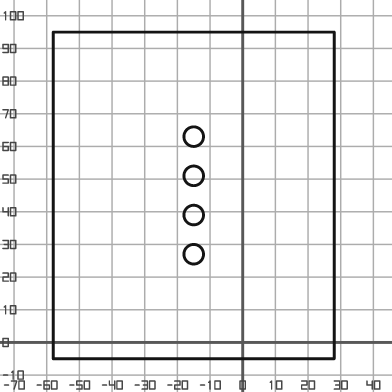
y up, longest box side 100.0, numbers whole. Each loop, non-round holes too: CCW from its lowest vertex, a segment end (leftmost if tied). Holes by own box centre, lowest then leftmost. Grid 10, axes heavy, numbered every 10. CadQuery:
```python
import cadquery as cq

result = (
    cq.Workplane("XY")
    .moveTo(-58.0, -5.0)
    .lineTo(28.0, -5.0)
    .lineTo(28.0, 95.0)
    .lineTo(-58.0, 95.0)
    .close()
    .moveTo(-15.0, 27.0)
    .circle(3.0)
    .moveTo(-15.0, 39.0)
    .circle(3.0)
    .moveTo(-15.0, 51.0)
    .circle(3.0)
    .moveTo(-15.0, 63.0)
    .circle(3.0)
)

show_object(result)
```